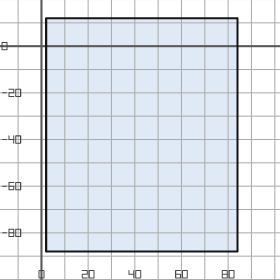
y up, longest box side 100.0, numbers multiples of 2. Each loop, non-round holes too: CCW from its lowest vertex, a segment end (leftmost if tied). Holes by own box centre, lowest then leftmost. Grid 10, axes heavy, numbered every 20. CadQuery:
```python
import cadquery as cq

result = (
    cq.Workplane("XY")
    .moveTo(2.0, -88.0)
    .lineTo(84.0, -88.0)
    .lineTo(84.0, 12.0)
    .lineTo(2.0, 12.0)
    .close()
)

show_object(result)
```